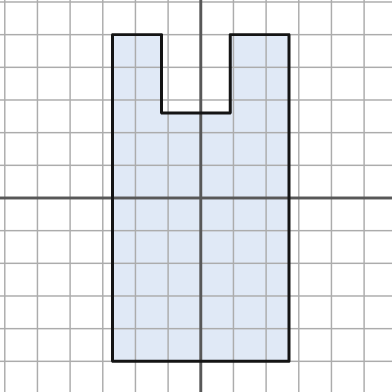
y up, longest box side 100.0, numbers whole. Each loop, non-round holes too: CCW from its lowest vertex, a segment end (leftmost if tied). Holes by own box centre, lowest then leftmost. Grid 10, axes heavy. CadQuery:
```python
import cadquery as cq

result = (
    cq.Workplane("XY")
    .moveTo(-27.0, -50.0)
    .lineTo(27.0, -50.0)
    .lineTo(27.0, 50.0)
    .lineTo(9.0, 50.0)
    .lineTo(9.0, 26.0)
    .lineTo(-12.0, 26.0)
    .lineTo(-12.0, 50.0)
    .lineTo(-27.0, 50.0)
    .close()
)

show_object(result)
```